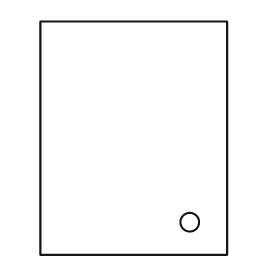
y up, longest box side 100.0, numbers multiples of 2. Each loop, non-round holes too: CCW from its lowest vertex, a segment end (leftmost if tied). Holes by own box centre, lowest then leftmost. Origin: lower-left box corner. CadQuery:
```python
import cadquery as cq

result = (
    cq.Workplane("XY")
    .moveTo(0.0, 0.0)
    .lineTo(80.0, 0.0)
    .lineTo(80.0, 100.0)
    .lineTo(0.0, 100.0)
    .close()
    .moveTo(64.0, 14.0)
    .circle(4.0)
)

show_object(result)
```